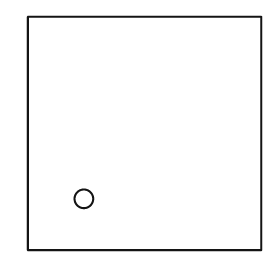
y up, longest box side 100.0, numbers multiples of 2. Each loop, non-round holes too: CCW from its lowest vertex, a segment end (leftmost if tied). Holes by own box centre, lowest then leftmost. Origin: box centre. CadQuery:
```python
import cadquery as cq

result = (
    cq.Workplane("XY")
    .moveTo(-50.0, -50.0)
    .lineTo(50.0, -50.0)
    .lineTo(50.0, 50.0)
    .lineTo(-50.0, 50.0)
    .close()
    .moveTo(-26.0, -28.0)
    .circle(4.0)
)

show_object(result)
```